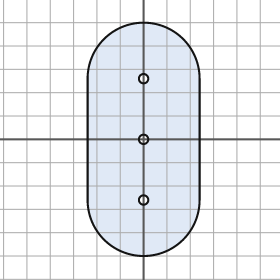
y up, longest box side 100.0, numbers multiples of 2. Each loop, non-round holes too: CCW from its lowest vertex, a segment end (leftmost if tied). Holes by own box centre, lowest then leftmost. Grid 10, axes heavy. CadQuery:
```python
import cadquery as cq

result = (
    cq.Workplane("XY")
    .moveTo(-24.0, -26.0)
    .threePointArc((0.0, -50.0), (24.0, -26.0))
    .lineTo(24.0, 26.0)
    .threePointArc((0.0, 50.0), (-24.0, 26.0))
    .close()
    .moveTo(0.0, -26.0)
    .circle(2.0)
    .moveTo(0.0, 0.0)
    .circle(2.0)
    .moveTo(0.0, 26.0)
    .circle(2.0)
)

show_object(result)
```